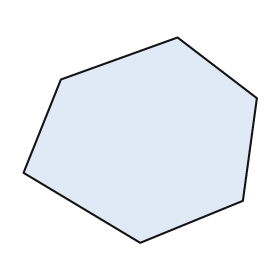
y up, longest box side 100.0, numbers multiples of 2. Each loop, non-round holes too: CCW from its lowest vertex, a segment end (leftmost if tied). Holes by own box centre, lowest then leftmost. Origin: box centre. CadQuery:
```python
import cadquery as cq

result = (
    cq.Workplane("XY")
    .moveTo(0.0, -44.0)
    .lineTo(44.0, -26.0)
    .lineTo(50.0, 18.0)
    .lineTo(16.0, 44.0)
    .lineTo(-34.0, 26.0)
    .lineTo(-50.0, -14.0)
    .close()
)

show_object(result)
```